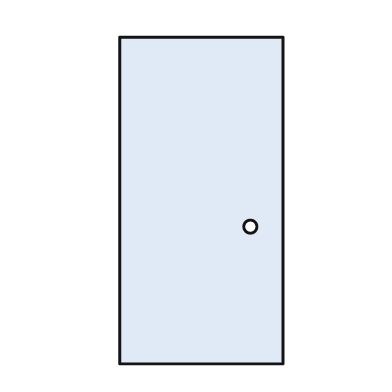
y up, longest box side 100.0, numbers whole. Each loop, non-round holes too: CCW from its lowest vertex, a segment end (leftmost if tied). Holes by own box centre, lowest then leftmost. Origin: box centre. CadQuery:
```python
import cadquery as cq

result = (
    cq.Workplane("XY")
    .moveTo(-25.0, -50.0)
    .lineTo(25.0, -50.0)
    .lineTo(25.0, 50.0)
    .lineTo(-25.0, 50.0)
    .close()
    .moveTo(15.0, -8.0)
    .circle(2.0)
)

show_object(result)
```